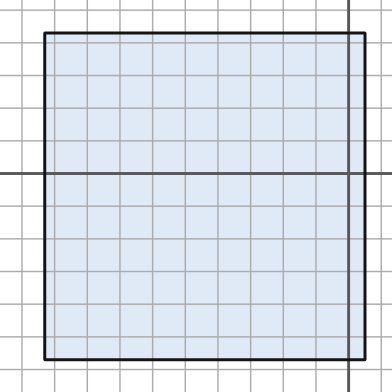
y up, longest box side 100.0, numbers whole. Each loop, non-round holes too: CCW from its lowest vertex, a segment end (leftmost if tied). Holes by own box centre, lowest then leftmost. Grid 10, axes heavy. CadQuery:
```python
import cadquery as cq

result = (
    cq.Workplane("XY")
    .moveTo(-93.0, -57.0)
    .lineTo(5.0, -57.0)
    .lineTo(5.0, 43.0)
    .lineTo(-93.0, 43.0)
    .close()
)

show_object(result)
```